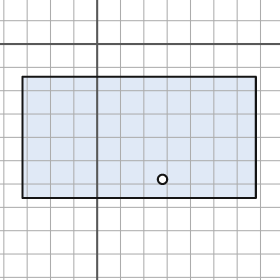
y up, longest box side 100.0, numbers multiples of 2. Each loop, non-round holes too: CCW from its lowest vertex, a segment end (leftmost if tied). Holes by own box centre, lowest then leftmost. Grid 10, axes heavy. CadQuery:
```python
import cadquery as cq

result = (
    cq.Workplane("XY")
    .moveTo(-32.0, -66.0)
    .lineTo(68.0, -66.0)
    .lineTo(68.0, -14.0)
    .lineTo(-32.0, -14.0)
    .close()
    .moveTo(28.0, -58.0)
    .circle(2.0)
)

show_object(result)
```